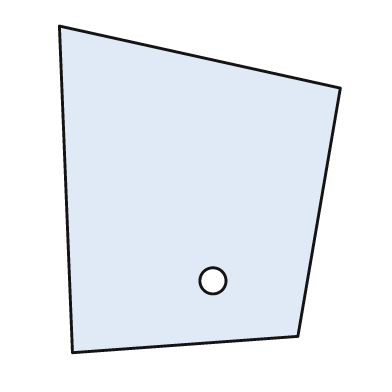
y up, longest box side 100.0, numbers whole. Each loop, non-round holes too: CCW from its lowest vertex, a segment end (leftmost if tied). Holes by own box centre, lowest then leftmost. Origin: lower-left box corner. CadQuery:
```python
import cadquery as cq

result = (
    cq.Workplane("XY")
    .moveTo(4.0, 0.0)
    .lineTo(73.0, 5.0)
    .lineTo(86.0, 81.0)
    .lineTo(0.0, 100.0)
    .close()
    .moveTo(47.0, 22.0)
    .circle(4.0)
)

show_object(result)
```